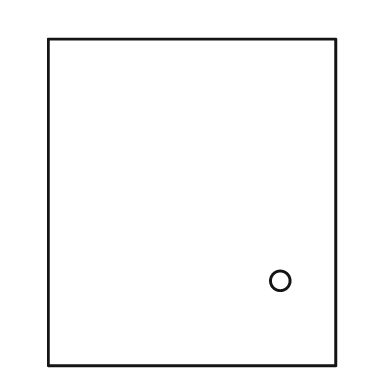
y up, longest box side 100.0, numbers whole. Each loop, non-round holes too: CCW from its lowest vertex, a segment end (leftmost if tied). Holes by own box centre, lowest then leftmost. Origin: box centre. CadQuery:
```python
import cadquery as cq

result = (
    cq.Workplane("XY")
    .moveTo(-44.0, -50.0)
    .lineTo(44.0, -50.0)
    .lineTo(44.0, 50.0)
    .lineTo(-44.0, 50.0)
    .close()
    .moveTo(27.0, -24.0)
    .circle(3.0)
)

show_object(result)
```